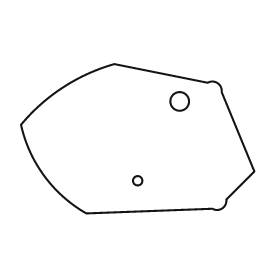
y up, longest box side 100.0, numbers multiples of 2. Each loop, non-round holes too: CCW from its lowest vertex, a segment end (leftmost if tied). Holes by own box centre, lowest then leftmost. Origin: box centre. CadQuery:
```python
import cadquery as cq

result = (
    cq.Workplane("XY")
    .moveTo(-22.0, -32.0)
    .lineTo(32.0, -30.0)
    .threePointArc((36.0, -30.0), (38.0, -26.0))
    .lineTo(50.0, -14.0)
    .lineTo(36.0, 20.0)
    .threePointArc((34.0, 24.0), (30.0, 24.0))
    .lineTo(-10.0, 32.0)
    .threePointArc((-32.0, 22.0), (-50.0, 6.0))
    .threePointArc((-40.0, -16.0), (-22.0, -32.0))
    .close()
    .moveTo(0.0, -18.0)
    .circle(2.0)
    .moveTo(18.0, 16.0)
    .circle(4.0)
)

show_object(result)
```